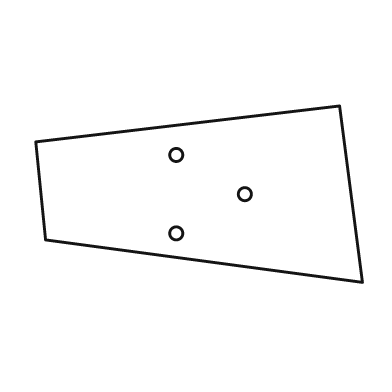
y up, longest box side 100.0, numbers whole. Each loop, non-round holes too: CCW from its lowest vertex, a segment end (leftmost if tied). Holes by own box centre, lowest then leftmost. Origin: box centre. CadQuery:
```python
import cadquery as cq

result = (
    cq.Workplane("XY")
    .moveTo(50.0, -27.0)
    .lineTo(43.0, 27.0)
    .lineTo(-50.0, 16.0)
    .lineTo(-47.0, -14.0)
    .close()
    .moveTo(-7.0, -12.0)
    .circle(2.0)
    .moveTo(14.0, 0.0)
    .circle(2.0)
    .moveTo(-7.0, 12.0)
    .circle(2.0)
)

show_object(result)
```